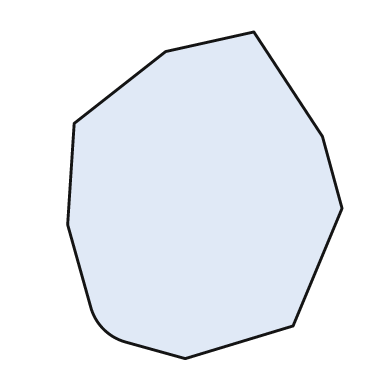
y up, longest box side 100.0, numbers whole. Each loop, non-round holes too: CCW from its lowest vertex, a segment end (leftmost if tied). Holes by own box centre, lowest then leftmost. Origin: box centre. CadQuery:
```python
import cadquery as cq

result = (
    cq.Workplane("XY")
    .moveTo(-6.0, -50.0)
    .lineTo(27.0, -40.0)
    .lineTo(42.0, -4.0)
    .lineTo(36.0, 18.0)
    .lineTo(15.0, 50.0)
    .lineTo(-12.0, 44.0)
    .lineTo(-40.0, 22.0)
    .lineTo(-42.0, -9.0)
    .lineTo(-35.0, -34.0)
    .threePointArc((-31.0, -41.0), (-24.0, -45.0))
    .close()
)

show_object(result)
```